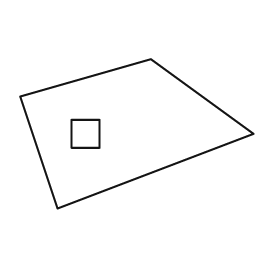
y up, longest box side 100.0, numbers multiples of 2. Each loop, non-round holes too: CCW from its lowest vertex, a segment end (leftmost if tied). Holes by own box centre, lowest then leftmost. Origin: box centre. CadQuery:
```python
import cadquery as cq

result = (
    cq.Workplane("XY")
    .moveTo(-34.0, -32.0)
    .lineTo(50.0, 0.0)
    .lineTo(6.0, 32.0)
    .lineTo(-50.0, 16.0)
    .close()
    .moveTo(-28.0, -6.0)
    .lineTo(-16.0, -6.0)
    .lineTo(-16.0, 6.0)
    .lineTo(-28.0, 6.0)
    .close()
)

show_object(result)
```